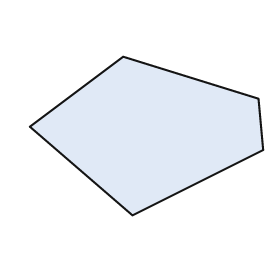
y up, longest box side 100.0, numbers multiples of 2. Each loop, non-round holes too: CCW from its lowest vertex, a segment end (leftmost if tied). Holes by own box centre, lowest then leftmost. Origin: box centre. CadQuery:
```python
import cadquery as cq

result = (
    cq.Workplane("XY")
    .moveTo(-6.0, -34.0)
    .lineTo(50.0, -6.0)
    .lineTo(48.0, 16.0)
    .lineTo(-10.0, 34.0)
    .lineTo(-50.0, 4.0)
    .close()
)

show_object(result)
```